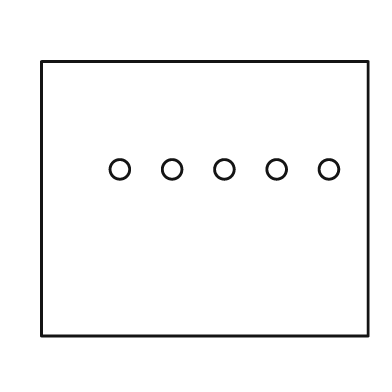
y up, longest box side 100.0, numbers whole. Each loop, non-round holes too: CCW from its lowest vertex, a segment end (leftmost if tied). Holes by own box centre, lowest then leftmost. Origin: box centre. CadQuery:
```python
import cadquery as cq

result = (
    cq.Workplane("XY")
    .moveTo(-50.0, -42.0)
    .lineTo(50.0, -42.0)
    .lineTo(50.0, 42.0)
    .lineTo(-50.0, 42.0)
    .close()
    .moveTo(-26.0, 9.0)
    .circle(3.0)
    .moveTo(-10.0, 9.0)
    .circle(3.0)
    .moveTo(6.0, 9.0)
    .circle(3.0)
    .moveTo(22.0, 9.0)
    .circle(3.0)
    .moveTo(38.0, 9.0)
    .circle(3.0)
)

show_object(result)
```